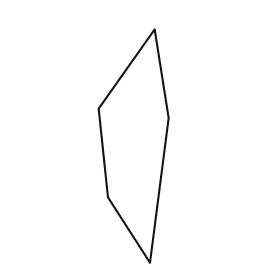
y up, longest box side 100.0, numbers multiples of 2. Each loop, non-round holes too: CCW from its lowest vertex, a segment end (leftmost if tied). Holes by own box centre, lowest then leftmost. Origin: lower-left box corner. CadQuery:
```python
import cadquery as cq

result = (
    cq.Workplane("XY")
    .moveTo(22.0, 0.0)
    .lineTo(30.0, 62.0)
    .lineTo(24.0, 100.0)
    .lineTo(0.0, 66.0)
    .lineTo(4.0, 28.0)
    .close()
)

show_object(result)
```